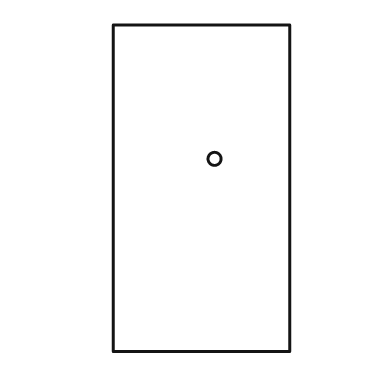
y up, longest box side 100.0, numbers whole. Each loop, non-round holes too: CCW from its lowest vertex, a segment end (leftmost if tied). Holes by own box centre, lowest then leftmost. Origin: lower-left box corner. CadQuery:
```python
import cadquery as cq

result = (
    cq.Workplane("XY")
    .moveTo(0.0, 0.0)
    .lineTo(54.0, 0.0)
    .lineTo(54.0, 100.0)
    .lineTo(0.0, 100.0)
    .close()
    .moveTo(31.0, 59.0)
    .circle(2.0)
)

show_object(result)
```